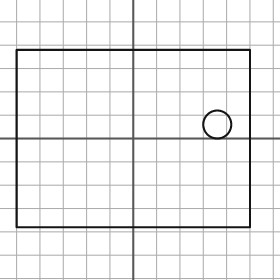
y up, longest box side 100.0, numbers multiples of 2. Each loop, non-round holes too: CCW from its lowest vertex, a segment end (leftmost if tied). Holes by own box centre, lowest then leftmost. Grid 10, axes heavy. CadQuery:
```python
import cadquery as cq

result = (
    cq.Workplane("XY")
    .moveTo(-50.0, -38.0)
    .lineTo(50.0, -38.0)
    .lineTo(50.0, 38.0)
    .lineTo(-50.0, 38.0)
    .close()
    .moveTo(36.0, 6.0)
    .circle(6.0)
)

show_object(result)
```